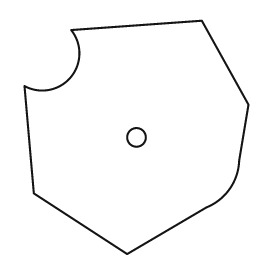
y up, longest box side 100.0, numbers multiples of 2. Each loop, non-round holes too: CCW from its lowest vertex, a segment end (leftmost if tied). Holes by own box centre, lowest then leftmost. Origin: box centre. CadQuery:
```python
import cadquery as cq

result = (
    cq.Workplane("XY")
    .moveTo(-4.0, -50.0)
    .lineTo(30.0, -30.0)
    .threePointArc((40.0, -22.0), (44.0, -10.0))
    .lineTo(48.0, 14.0)
    .lineTo(28.0, 50.0)
    .lineTo(-28.0, 46.0)
    .threePointArc((-28.0, 26.0), (-48.0, 22.0))
    .lineTo(-44.0, -24.0)
    .close()
    .moveTo(0.0, 0.0)
    .circle(4.0)
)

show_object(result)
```